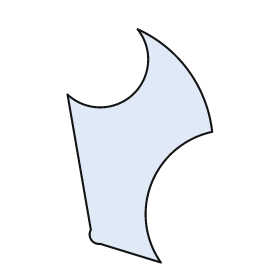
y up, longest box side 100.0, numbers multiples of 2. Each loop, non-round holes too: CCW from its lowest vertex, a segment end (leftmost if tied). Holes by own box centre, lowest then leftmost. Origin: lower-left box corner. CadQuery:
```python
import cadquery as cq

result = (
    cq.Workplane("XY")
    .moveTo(40.0, 0.0)
    .threePointArc((36.0, 34.0), (62.0, 56.0))
    .threePointArc((52.0, 82.0), (30.0, 100.0))
    .threePointArc((28.0, 72.0), (0.0, 72.0))
    .lineTo(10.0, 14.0)
    .threePointArc((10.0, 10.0), (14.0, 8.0))
    .close()
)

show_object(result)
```